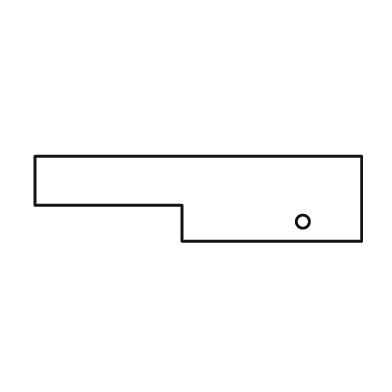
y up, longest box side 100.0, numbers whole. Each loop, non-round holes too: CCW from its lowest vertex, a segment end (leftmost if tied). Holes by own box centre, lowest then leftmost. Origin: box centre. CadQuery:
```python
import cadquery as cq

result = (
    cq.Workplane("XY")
    .moveTo(-5.0, -13.0)
    .lineTo(50.0, -13.0)
    .lineTo(50.0, 13.0)
    .lineTo(-50.0, 13.0)
    .lineTo(-50.0, -2.0)
    .lineTo(-5.0, -2.0)
    .close()
    .moveTo(32.0, -7.0)
    .circle(2.0)
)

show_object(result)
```